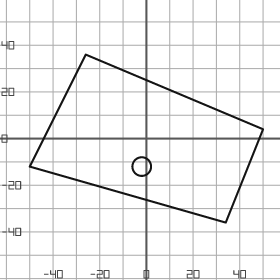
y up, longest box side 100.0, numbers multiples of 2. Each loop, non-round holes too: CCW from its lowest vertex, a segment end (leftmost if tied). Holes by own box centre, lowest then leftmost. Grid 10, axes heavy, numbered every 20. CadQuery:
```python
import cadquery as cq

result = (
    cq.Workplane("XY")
    .moveTo(34.0, -36.0)
    .lineTo(50.0, 4.0)
    .lineTo(-26.0, 36.0)
    .lineTo(-50.0, -12.0)
    .close()
    .moveTo(-2.0, -12.0)
    .circle(4.0)
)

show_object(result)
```